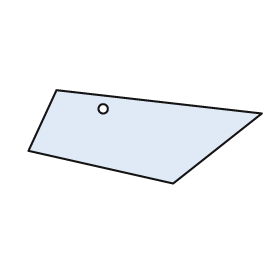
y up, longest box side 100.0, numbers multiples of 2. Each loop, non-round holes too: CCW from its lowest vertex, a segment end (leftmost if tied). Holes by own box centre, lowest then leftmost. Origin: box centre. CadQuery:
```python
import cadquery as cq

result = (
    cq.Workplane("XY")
    .moveTo(12.0, -20.0)
    .lineTo(50.0, 10.0)
    .lineTo(-38.0, 20.0)
    .lineTo(-50.0, -6.0)
    .close()
    .moveTo(-18.0, 12.0)
    .circle(2.0)
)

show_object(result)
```